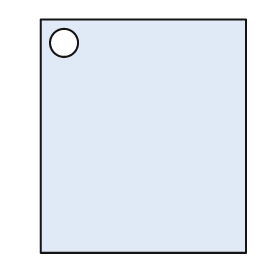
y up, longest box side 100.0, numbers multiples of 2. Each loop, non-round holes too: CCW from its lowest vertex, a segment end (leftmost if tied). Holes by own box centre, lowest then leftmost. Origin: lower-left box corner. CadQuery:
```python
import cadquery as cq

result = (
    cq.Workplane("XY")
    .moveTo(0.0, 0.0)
    .lineTo(88.0, 0.0)
    .lineTo(88.0, 100.0)
    .lineTo(0.0, 100.0)
    .close()
    .moveTo(10.0, 90.0)
    .circle(6.0)
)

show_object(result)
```